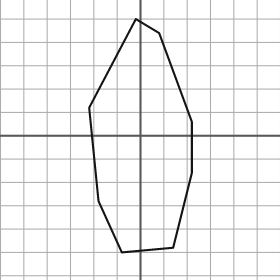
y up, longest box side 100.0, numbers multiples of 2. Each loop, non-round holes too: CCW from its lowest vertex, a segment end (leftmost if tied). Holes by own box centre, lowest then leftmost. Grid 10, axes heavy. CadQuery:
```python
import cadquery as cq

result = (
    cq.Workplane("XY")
    .moveTo(-8.0, -50.0)
    .lineTo(14.0, -48.0)
    .lineTo(22.0, -16.0)
    .lineTo(22.0, 6.0)
    .lineTo(8.0, 44.0)
    .lineTo(-2.0, 50.0)
    .lineTo(-22.0, 12.0)
    .lineTo(-18.0, -28.0)
    .close()
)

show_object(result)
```